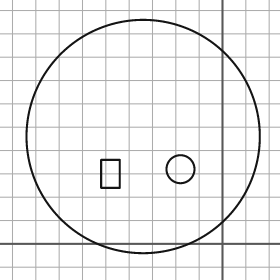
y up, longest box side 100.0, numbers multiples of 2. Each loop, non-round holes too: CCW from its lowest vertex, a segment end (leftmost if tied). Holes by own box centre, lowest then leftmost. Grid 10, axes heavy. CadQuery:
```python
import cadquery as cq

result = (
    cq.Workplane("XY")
    .moveTo(-34.0, 46.0)
    .circle(50.0)
    .moveTo(-52.0, 24.0)
    .lineTo(-44.0, 24.0)
    .lineTo(-44.0, 36.0)
    .lineTo(-52.0, 36.0)
    .close()
    .moveTo(-18.0, 32.0)
    .circle(6.0)
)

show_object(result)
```